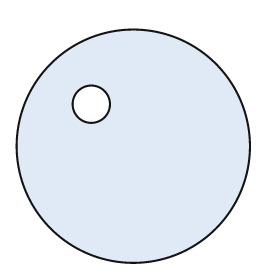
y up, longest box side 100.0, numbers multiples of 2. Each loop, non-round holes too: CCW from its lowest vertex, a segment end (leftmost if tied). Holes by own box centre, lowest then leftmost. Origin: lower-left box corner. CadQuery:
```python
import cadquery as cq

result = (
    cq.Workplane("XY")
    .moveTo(50.0, 50.0)
    .circle(50.0)
    .moveTo(32.0, 68.0)
    .circle(8.0)
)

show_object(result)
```